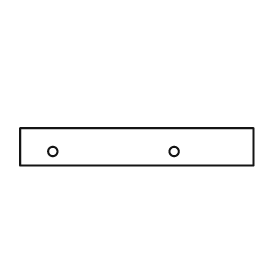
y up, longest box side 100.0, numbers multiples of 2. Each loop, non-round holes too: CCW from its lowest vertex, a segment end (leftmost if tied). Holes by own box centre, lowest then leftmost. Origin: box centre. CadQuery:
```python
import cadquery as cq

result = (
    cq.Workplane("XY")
    .moveTo(-50.0, -8.0)
    .lineTo(50.0, -8.0)
    .lineTo(50.0, 8.0)
    .lineTo(-50.0, 8.0)
    .close()
    .moveTo(-36.0, -2.0)
    .circle(2.0)
    .moveTo(16.0, -2.0)
    .circle(2.0)
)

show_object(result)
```